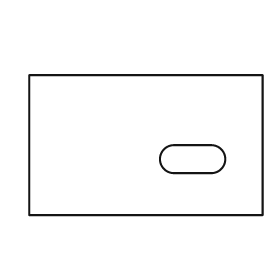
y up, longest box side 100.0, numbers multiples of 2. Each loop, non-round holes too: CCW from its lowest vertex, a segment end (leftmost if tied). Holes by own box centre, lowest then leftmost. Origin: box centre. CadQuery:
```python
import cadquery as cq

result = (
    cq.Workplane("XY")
    .moveTo(-50.0, -30.0)
    .lineTo(50.0, -30.0)
    .lineTo(50.0, 30.0)
    .lineTo(-50.0, 30.0)
    .close()
    .moveTo(12.0, -12.0)
    .lineTo(28.0, -12.0)
    .threePointArc((34.0, -6.0), (28.0, 0.0))
    .lineTo(12.0, 0.0)
    .threePointArc((6.0, -6.0), (12.0, -12.0))
    .close()
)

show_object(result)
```